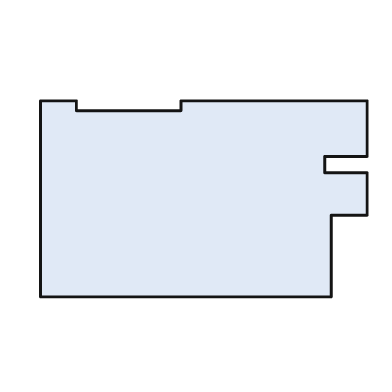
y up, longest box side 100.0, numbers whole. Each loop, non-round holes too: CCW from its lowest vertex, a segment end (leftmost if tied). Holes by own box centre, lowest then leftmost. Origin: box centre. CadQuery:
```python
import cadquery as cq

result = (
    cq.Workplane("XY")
    .moveTo(-50.0, -30.0)
    .lineTo(39.0, -30.0)
    .lineTo(39.0, -5.0)
    .lineTo(50.0, -5.0)
    .lineTo(50.0, 8.0)
    .lineTo(37.0, 8.0)
    .lineTo(37.0, 13.0)
    .lineTo(50.0, 13.0)
    .lineTo(50.0, 30.0)
    .lineTo(-7.0, 30.0)
    .lineTo(-7.0, 27.0)
    .lineTo(-39.0, 27.0)
    .lineTo(-39.0, 30.0)
    .lineTo(-50.0, 30.0)
    .close()
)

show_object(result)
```